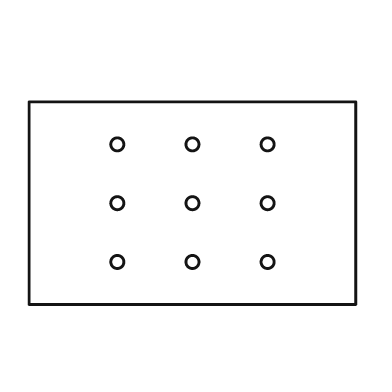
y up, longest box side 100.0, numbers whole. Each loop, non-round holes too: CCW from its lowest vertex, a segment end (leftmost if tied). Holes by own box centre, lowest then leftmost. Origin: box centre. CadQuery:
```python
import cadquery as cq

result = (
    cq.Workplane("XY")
    .moveTo(-50.0, -31.0)
    .lineTo(50.0, -31.0)
    .lineTo(50.0, 31.0)
    .lineTo(-50.0, 31.0)
    .close()
    .moveTo(-23.0, -18.0)
    .circle(2.0)
    .moveTo(0.0, -18.0)
    .circle(2.0)
    .moveTo(23.0, -18.0)
    .circle(2.0)
    .moveTo(-23.0, 0.0)
    .circle(2.0)
    .moveTo(0.0, 0.0)
    .circle(2.0)
    .moveTo(23.0, 0.0)
    .circle(2.0)
    .moveTo(-23.0, 18.0)
    .circle(2.0)
    .moveTo(0.0, 18.0)
    .circle(2.0)
    .moveTo(23.0, 18.0)
    .circle(2.0)
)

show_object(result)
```